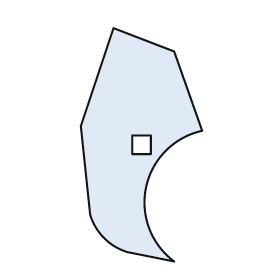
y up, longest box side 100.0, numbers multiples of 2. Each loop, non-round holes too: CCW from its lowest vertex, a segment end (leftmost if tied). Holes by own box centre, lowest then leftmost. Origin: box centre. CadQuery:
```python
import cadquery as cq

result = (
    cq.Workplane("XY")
    .moveTo(14.0, -50.0)
    .threePointArc((2.0, -18.0), (26.0, 6.0))
    .lineTo(14.0, 40.0)
    .lineTo(-12.0, 50.0)
    .lineTo(-26.0, 8.0)
    .lineTo(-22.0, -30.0)
    .threePointArc((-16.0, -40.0), (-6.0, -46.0))
    .close()
    .moveTo(-4.0, -4.0)
    .lineTo(4.0, -4.0)
    .lineTo(4.0, 4.0)
    .lineTo(-4.0, 4.0)
    .close()
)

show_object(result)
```